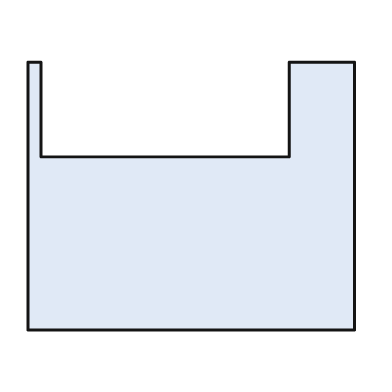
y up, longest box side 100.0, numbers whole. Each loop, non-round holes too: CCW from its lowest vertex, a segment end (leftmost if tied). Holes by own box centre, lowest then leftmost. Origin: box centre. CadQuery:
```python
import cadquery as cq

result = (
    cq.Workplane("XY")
    .moveTo(-50.0, -41.0)
    .lineTo(50.0, -41.0)
    .lineTo(50.0, 41.0)
    .lineTo(30.0, 41.0)
    .lineTo(30.0, 12.0)
    .lineTo(-46.0, 12.0)
    .lineTo(-46.0, 41.0)
    .lineTo(-50.0, 41.0)
    .close()
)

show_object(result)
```